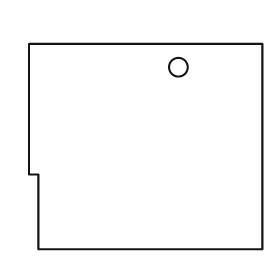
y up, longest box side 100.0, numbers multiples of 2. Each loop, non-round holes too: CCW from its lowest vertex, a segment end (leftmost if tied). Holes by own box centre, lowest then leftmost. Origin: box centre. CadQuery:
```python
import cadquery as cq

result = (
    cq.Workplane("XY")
    .moveTo(-46.0, -44.0)
    .lineTo(50.0, -44.0)
    .lineTo(50.0, 44.0)
    .lineTo(-50.0, 44.0)
    .lineTo(-50.0, -12.0)
    .lineTo(-46.0, -12.0)
    .close()
    .moveTo(14.0, 34.0)
    .circle(4.0)
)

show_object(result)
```